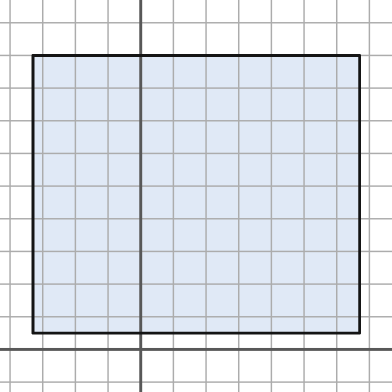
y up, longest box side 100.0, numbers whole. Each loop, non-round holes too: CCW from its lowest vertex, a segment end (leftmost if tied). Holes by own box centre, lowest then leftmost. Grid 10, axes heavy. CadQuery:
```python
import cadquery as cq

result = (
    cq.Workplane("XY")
    .moveTo(-33.0, 5.0)
    .lineTo(67.0, 5.0)
    .lineTo(67.0, 90.0)
    .lineTo(-33.0, 90.0)
    .close()
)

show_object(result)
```